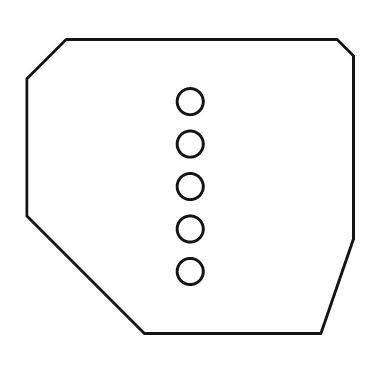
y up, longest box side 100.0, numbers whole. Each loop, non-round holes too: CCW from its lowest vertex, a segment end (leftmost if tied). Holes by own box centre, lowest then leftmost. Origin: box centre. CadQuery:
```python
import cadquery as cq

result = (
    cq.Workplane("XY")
    .moveTo(-14.0, -45.0)
    .lineTo(40.0, -45.0)
    .lineTo(50.0, -16.0)
    .lineTo(50.0, 40.0)
    .lineTo(45.0, 45.0)
    .lineTo(-38.0, 45.0)
    .lineTo(-50.0, 33.0)
    .lineTo(-50.0, -9.0)
    .close()
    .moveTo(0.0, -26.0)
    .circle(4.0)
    .moveTo(0.0, -13.0)
    .circle(4.0)
    .moveTo(0.0, 0.0)
    .circle(4.0)
    .moveTo(0.0, 13.0)
    .circle(4.0)
    .moveTo(0.0, 26.0)
    .circle(4.0)
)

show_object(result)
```